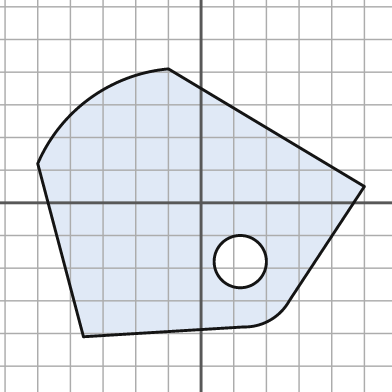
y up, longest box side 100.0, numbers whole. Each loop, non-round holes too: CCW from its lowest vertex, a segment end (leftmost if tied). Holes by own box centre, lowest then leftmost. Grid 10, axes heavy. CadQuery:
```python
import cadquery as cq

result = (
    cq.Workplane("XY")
    .moveTo(-36.0, -41.0)
    .lineTo(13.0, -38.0)
    .threePointArc((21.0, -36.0), (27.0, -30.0))
    .lineTo(50.0, 5.0)
    .lineTo(-10.0, 41.0)
    .threePointArc((-34.0, 32.0), (-50.0, 12.0))
    .close()
    .moveTo(12.0, -18.0)
    .circle(8.0)
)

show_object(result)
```